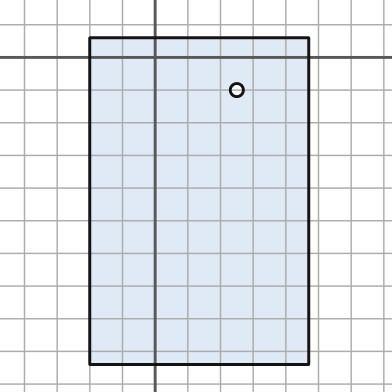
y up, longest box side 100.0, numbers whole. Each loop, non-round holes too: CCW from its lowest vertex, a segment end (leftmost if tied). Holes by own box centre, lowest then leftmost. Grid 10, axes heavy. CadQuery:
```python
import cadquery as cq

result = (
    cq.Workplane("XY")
    .moveTo(-20.0, -94.0)
    .lineTo(47.0, -94.0)
    .lineTo(47.0, 6.0)
    .lineTo(-20.0, 6.0)
    .close()
    .moveTo(25.0, -10.0)
    .circle(2.0)
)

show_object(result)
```